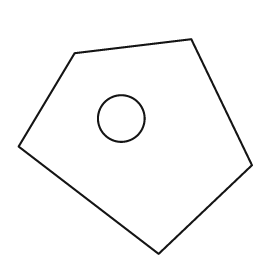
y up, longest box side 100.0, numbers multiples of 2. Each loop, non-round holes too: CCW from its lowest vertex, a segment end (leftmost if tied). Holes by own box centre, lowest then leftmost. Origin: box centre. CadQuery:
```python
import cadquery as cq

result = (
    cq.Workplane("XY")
    .moveTo(10.0, -46.0)
    .lineTo(50.0, -8.0)
    .lineTo(24.0, 46.0)
    .lineTo(-26.0, 40.0)
    .lineTo(-50.0, 0.0)
    .close()
    .moveTo(-6.0, 12.0)
    .circle(10.0)
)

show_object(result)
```